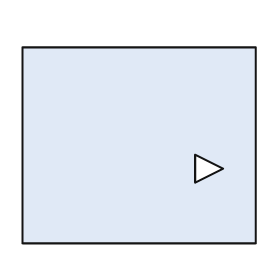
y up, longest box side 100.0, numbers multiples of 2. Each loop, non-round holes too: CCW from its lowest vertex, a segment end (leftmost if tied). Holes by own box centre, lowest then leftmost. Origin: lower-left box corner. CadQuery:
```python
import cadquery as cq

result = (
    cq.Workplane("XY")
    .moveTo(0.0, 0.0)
    .lineTo(100.0, 0.0)
    .lineTo(100.0, 84.0)
    .lineTo(0.0, 84.0)
    .close()
    .moveTo(74.0, 26.0)
    .lineTo(86.0, 32.0)
    .lineTo(74.0, 38.0)
    .close()
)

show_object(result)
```